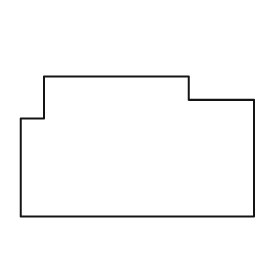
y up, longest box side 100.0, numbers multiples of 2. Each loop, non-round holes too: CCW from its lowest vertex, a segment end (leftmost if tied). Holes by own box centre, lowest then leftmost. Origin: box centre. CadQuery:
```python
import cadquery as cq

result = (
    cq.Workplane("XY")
    .moveTo(-50.0, -30.0)
    .lineTo(50.0, -30.0)
    .lineTo(50.0, 20.0)
    .lineTo(22.0, 20.0)
    .lineTo(22.0, 30.0)
    .lineTo(-40.0, 30.0)
    .lineTo(-40.0, 12.0)
    .lineTo(-50.0, 12.0)
    .close()
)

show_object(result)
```